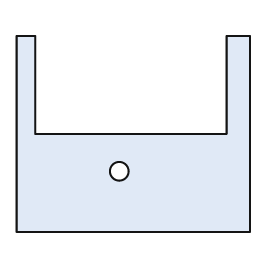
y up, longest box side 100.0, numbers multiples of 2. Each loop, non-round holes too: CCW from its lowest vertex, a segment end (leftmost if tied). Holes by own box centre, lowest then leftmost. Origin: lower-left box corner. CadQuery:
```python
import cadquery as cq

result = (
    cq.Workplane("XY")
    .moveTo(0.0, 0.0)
    .lineTo(100.0, 0.0)
    .lineTo(100.0, 84.0)
    .lineTo(90.0, 84.0)
    .lineTo(90.0, 42.0)
    .lineTo(8.0, 42.0)
    .lineTo(8.0, 84.0)
    .lineTo(0.0, 84.0)
    .close()
    .moveTo(44.0, 26.0)
    .circle(4.0)
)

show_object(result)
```